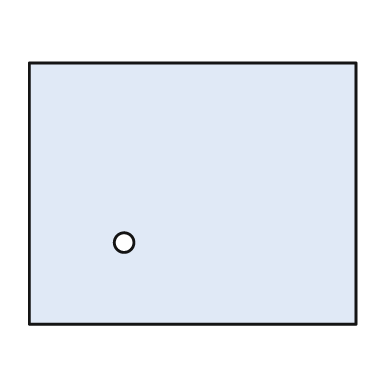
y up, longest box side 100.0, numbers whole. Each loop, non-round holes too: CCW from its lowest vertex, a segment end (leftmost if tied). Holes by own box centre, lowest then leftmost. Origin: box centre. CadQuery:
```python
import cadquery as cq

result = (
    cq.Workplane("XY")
    .moveTo(-50.0, -40.0)
    .lineTo(50.0, -40.0)
    .lineTo(50.0, 40.0)
    .lineTo(-50.0, 40.0)
    .close()
    .moveTo(-21.0, -15.0)
    .circle(3.0)
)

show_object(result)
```